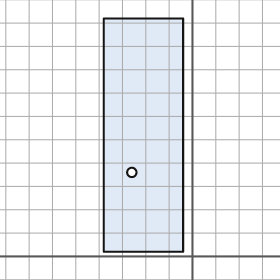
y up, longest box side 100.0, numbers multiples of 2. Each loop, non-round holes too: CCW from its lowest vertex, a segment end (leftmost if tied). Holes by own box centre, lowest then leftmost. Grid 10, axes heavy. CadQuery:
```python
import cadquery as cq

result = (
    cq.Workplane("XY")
    .moveTo(-38.0, 2.0)
    .lineTo(-4.0, 2.0)
    .lineTo(-4.0, 102.0)
    .lineTo(-38.0, 102.0)
    .close()
    .moveTo(-26.0, 36.0)
    .circle(2.0)
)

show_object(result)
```